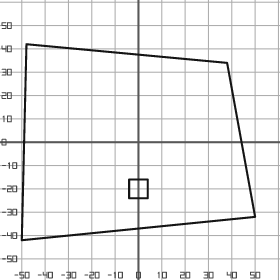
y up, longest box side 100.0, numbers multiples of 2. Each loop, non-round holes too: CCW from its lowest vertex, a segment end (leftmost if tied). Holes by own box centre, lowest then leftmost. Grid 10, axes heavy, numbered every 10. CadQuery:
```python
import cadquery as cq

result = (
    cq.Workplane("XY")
    .moveTo(-50.0, -42.0)
    .lineTo(50.0, -32.0)
    .lineTo(38.0, 34.0)
    .lineTo(-48.0, 42.0)
    .close()
    .moveTo(-4.0, -24.0)
    .lineTo(4.0, -24.0)
    .lineTo(4.0, -16.0)
    .lineTo(-4.0, -16.0)
    .close()
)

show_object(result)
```